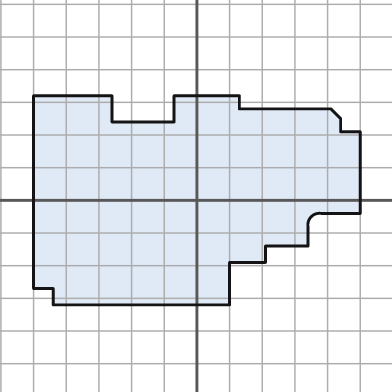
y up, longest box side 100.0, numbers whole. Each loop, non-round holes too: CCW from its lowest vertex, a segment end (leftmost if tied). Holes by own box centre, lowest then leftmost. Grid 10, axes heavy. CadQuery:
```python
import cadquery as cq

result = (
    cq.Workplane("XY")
    .moveTo(-44.0, -32.0)
    .lineTo(10.0, -32.0)
    .lineTo(10.0, -19.0)
    .lineTo(21.0, -19.0)
    .lineTo(21.0, -14.0)
    .lineTo(34.0, -14.0)
    .lineTo(34.0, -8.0)
    .threePointArc((35.0, -5.0), (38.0, -4.0))
    .lineTo(50.0, -4.0)
    .lineTo(50.0, 21.0)
    .lineTo(44.0, 21.0)
    .lineTo(44.0, 25.0)
    .lineTo(41.0, 28.0)
    .lineTo(13.0, 28.0)
    .lineTo(13.0, 32.0)
    .lineTo(-7.0, 32.0)
    .lineTo(-7.0, 24.0)
    .lineTo(-26.0, 24.0)
    .lineTo(-26.0, 32.0)
    .lineTo(-50.0, 32.0)
    .lineTo(-50.0, -27.0)
    .lineTo(-44.0, -27.0)
    .close()
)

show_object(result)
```